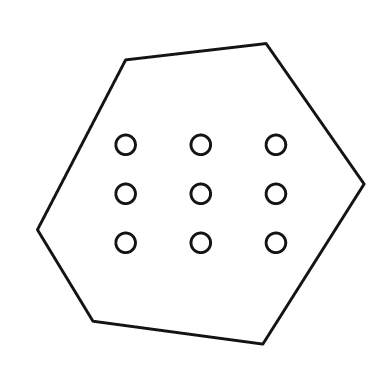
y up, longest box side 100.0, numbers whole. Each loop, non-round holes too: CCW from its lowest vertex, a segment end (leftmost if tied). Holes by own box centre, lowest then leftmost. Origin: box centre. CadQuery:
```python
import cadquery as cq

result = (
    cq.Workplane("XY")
    .moveTo(19.0, -46.0)
    .lineTo(50.0, 3.0)
    .lineTo(20.0, 46.0)
    .lineTo(-23.0, 41.0)
    .lineTo(-50.0, -11.0)
    .lineTo(-33.0, -39.0)
    .close()
    .moveTo(-23.0, -15.0)
    .circle(3.0)
    .moveTo(0.0, -15.0)
    .circle(3.0)
    .moveTo(23.0, -15.0)
    .circle(3.0)
    .moveTo(-23.0, 0.0)
    .circle(3.0)
    .moveTo(0.0, 0.0)
    .circle(3.0)
    .moveTo(23.0, 0.0)
    .circle(3.0)
    .moveTo(-23.0, 15.0)
    .circle(3.0)
    .moveTo(0.0, 15.0)
    .circle(3.0)
    .moveTo(23.0, 15.0)
    .circle(3.0)
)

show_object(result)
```